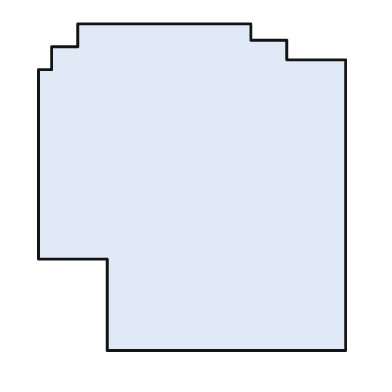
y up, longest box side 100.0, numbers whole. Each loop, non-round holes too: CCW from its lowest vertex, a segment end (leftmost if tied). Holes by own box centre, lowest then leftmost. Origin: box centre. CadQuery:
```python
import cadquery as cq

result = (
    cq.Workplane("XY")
    .moveTo(-26.0, -50.0)
    .lineTo(47.0, -50.0)
    .lineTo(47.0, 39.0)
    .lineTo(29.0, 39.0)
    .lineTo(29.0, 45.0)
    .lineTo(18.0, 45.0)
    .lineTo(18.0, 50.0)
    .lineTo(-35.0, 50.0)
    .lineTo(-35.0, 43.0)
    .lineTo(-43.0, 43.0)
    .lineTo(-43.0, 36.0)
    .lineTo(-47.0, 36.0)
    .lineTo(-47.0, -22.0)
    .lineTo(-26.0, -22.0)
    .close()
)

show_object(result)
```